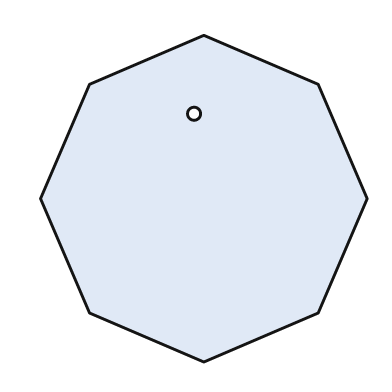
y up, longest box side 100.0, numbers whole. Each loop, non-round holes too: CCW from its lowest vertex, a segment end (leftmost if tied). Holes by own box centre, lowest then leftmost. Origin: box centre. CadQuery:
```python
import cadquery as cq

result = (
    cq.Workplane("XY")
    .moveTo(0.0, -50.0)
    .lineTo(35.0, -35.0)
    .lineTo(50.0, 0.0)
    .lineTo(35.0, 35.0)
    .lineTo(0.0, 50.0)
    .lineTo(-35.0, 35.0)
    .lineTo(-50.0, 0.0)
    .lineTo(-35.0, -35.0)
    .close()
    .moveTo(-3.0, 26.0)
    .circle(2.0)
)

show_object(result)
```